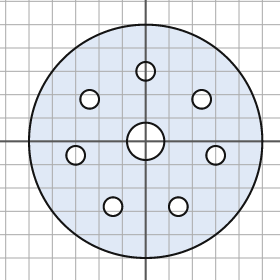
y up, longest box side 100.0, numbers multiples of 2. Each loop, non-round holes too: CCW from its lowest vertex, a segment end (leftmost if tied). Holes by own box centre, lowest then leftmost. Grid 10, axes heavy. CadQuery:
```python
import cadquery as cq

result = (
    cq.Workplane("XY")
    .moveTo(0.0, 0.0)
    .circle(50.0)
    .moveTo(-14.0, -28.0)
    .circle(4.0)
    .moveTo(14.0, -28.0)
    .circle(4.0)
    .moveTo(-30.0, -6.0)
    .circle(4.0)
    .moveTo(30.0, -6.0)
    .circle(4.0)
    .moveTo(0.0, 0.0)
    .circle(8.0)
    .moveTo(-24.0, 18.0)
    .circle(4.0)
    .moveTo(24.0, 18.0)
    .circle(4.0)
    .moveTo(0.0, 30.0)
    .circle(4.0)
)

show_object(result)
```